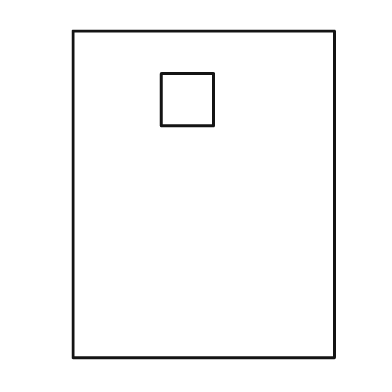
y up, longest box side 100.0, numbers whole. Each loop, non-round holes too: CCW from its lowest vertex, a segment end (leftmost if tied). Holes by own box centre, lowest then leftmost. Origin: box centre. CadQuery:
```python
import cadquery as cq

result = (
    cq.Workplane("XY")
    .moveTo(-40.0, -50.0)
    .lineTo(40.0, -50.0)
    .lineTo(40.0, 50.0)
    .lineTo(-40.0, 50.0)
    .close()
    .moveTo(-13.0, 21.0)
    .lineTo(3.0, 21.0)
    .lineTo(3.0, 37.0)
    .lineTo(-13.0, 37.0)
    .close()
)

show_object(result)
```